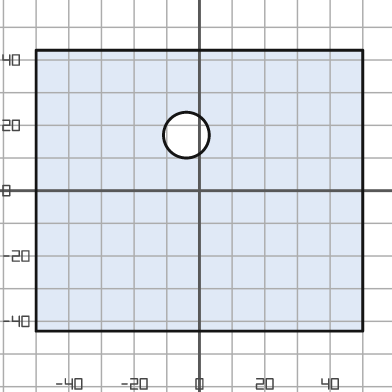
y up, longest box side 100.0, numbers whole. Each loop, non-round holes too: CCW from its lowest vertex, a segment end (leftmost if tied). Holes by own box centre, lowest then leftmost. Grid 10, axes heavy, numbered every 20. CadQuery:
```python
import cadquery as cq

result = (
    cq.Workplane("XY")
    .moveTo(-50.0, -43.0)
    .lineTo(50.0, -43.0)
    .lineTo(50.0, 43.0)
    .lineTo(-50.0, 43.0)
    .close()
    .moveTo(-4.0, 17.0)
    .circle(7.0)
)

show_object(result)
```